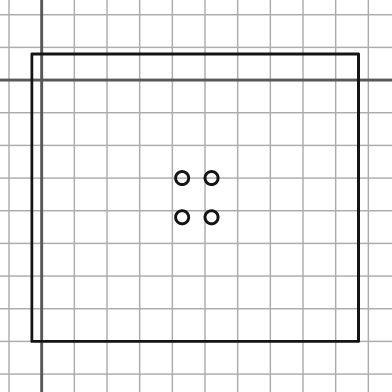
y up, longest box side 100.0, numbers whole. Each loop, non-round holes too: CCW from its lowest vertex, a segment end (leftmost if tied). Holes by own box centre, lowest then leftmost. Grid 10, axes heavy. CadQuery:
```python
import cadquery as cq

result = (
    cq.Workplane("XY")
    .moveTo(-3.0, -80.0)
    .lineTo(97.0, -80.0)
    .lineTo(97.0, 8.0)
    .lineTo(-3.0, 8.0)
    .close()
    .moveTo(43.0, -42.0)
    .circle(2.0)
    .moveTo(52.0, -42.0)
    .circle(2.0)
    .moveTo(43.0, -30.0)
    .circle(2.0)
    .moveTo(52.0, -30.0)
    .circle(2.0)
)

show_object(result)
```